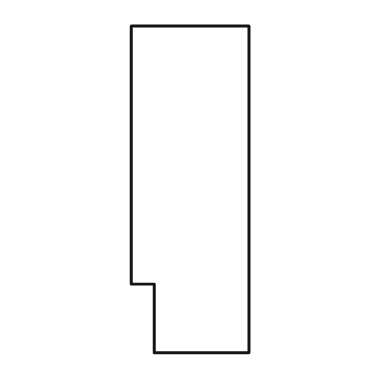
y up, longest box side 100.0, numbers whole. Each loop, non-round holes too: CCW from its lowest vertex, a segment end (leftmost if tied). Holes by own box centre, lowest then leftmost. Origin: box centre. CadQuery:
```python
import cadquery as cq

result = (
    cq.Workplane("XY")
    .moveTo(-11.0, -50.0)
    .lineTo(18.0, -50.0)
    .lineTo(18.0, 50.0)
    .lineTo(-18.0, 50.0)
    .lineTo(-18.0, -29.0)
    .lineTo(-11.0, -29.0)
    .close()
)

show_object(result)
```